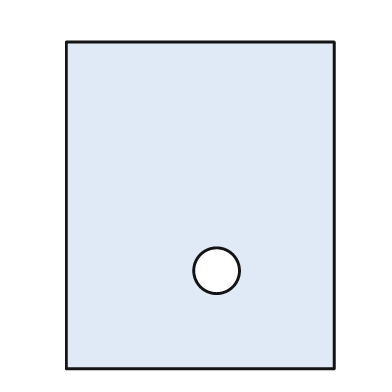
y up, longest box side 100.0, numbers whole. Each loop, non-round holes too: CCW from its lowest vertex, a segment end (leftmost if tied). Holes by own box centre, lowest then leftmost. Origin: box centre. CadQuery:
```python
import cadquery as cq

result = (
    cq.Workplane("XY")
    .moveTo(-41.0, -50.0)
    .lineTo(41.0, -50.0)
    .lineTo(41.0, 50.0)
    .lineTo(-41.0, 50.0)
    .close()
    .moveTo(5.0, -20.0)
    .circle(7.0)
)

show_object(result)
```